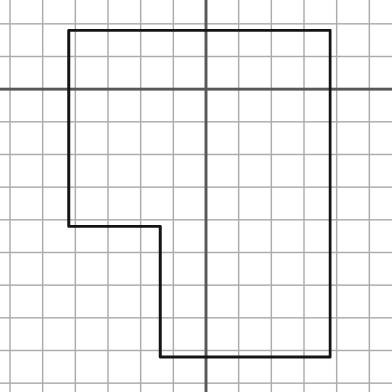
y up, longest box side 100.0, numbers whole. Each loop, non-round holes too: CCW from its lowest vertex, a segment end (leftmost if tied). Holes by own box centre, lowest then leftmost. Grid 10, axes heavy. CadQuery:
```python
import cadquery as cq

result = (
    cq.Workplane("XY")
    .moveTo(-14.0, -82.0)
    .lineTo(38.0, -82.0)
    .lineTo(38.0, 18.0)
    .lineTo(-42.0, 18.0)
    .lineTo(-42.0, -42.0)
    .lineTo(-14.0, -42.0)
    .close()
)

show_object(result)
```